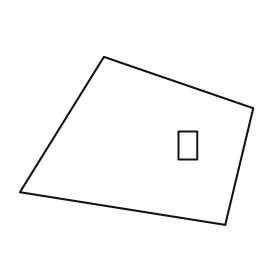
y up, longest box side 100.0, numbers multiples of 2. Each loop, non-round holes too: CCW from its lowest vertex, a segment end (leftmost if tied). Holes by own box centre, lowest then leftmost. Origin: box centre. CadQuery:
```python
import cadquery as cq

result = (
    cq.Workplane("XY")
    .moveTo(38.0, -36.0)
    .lineTo(50.0, 14.0)
    .lineTo(-14.0, 36.0)
    .lineTo(-50.0, -22.0)
    .close()
    .moveTo(18.0, -8.0)
    .lineTo(26.0, -8.0)
    .lineTo(26.0, 4.0)
    .lineTo(18.0, 4.0)
    .close()
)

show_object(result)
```